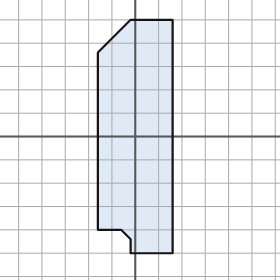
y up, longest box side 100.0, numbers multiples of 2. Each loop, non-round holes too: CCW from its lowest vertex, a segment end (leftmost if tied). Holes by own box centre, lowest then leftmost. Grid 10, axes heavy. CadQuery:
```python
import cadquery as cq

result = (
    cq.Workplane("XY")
    .moveTo(-2.0, -50.0)
    .lineTo(16.0, -50.0)
    .lineTo(16.0, 50.0)
    .lineTo(-2.0, 50.0)
    .lineTo(-16.0, 36.0)
    .lineTo(-16.0, -40.0)
    .lineTo(-6.0, -40.0)
    .lineTo(-2.0, -44.0)
    .close()
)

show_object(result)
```